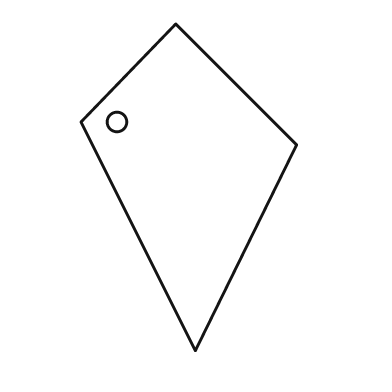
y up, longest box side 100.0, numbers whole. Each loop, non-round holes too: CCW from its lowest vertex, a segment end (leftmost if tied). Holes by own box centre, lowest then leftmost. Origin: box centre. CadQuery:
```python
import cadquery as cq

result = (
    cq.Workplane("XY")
    .moveTo(2.0, -50.0)
    .lineTo(33.0, 13.0)
    .lineTo(-4.0, 50.0)
    .lineTo(-33.0, 20.0)
    .close()
    .moveTo(-22.0, 20.0)
    .circle(3.0)
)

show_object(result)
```